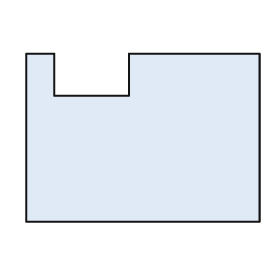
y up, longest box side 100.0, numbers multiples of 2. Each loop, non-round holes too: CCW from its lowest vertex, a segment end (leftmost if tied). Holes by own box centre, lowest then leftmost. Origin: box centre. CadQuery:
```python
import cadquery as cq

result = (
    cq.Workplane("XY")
    .moveTo(-50.0, -36.0)
    .lineTo(50.0, -36.0)
    .lineTo(50.0, 36.0)
    .lineTo(-6.0, 36.0)
    .lineTo(-6.0, 18.0)
    .lineTo(-38.0, 18.0)
    .lineTo(-38.0, 36.0)
    .lineTo(-50.0, 36.0)
    .close()
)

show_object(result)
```